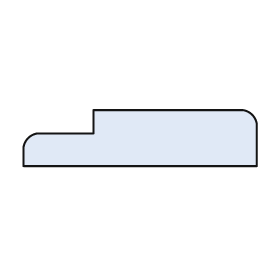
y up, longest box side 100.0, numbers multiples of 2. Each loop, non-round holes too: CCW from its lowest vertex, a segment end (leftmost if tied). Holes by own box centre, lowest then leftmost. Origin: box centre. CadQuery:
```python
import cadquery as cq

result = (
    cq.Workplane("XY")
    .moveTo(-50.0, -12.0)
    .lineTo(50.0, -12.0)
    .lineTo(50.0, 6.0)
    .threePointArc((48.0, 10.0), (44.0, 12.0))
    .lineTo(-20.0, 12.0)
    .lineTo(-20.0, 2.0)
    .lineTo(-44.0, 2.0)
    .threePointArc((-48.0, 0.0), (-50.0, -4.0))
    .close()
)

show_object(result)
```